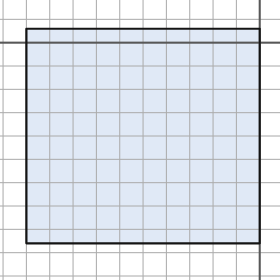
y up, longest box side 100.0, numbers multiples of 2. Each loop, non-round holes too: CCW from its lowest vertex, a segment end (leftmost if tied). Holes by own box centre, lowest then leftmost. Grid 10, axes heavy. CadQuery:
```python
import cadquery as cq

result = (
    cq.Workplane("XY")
    .moveTo(-100.0, -86.0)
    .lineTo(0.0, -86.0)
    .lineTo(0.0, 6.0)
    .lineTo(-100.0, 6.0)
    .close()
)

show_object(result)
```